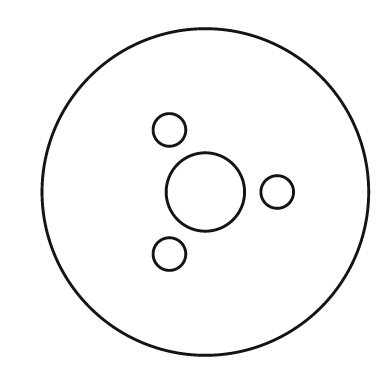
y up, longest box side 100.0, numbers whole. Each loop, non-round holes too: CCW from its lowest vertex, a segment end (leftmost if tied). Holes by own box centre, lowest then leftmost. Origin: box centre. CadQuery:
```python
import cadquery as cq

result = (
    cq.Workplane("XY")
    .moveTo(0.0, 0.0)
    .circle(50.0)
    .moveTo(-11.0, -19.0)
    .circle(5.0)
    .moveTo(0.0, 0.0)
    .circle(12.0)
    .moveTo(22.0, 0.0)
    .circle(5.0)
    .moveTo(-11.0, 19.0)
    .circle(5.0)
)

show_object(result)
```